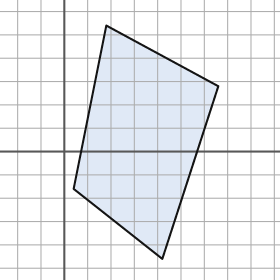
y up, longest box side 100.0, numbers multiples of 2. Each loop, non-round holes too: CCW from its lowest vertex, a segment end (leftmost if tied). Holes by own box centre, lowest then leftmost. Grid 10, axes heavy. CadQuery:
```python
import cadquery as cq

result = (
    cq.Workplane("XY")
    .moveTo(42.0, -46.0)
    .lineTo(66.0, 28.0)
    .lineTo(18.0, 54.0)
    .lineTo(4.0, -16.0)
    .close()
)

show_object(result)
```